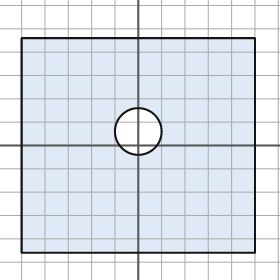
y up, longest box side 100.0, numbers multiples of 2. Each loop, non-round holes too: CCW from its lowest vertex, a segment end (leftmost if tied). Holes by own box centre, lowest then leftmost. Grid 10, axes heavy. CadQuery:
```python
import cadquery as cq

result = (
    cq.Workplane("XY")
    .moveTo(-50.0, -46.0)
    .lineTo(50.0, -46.0)
    .lineTo(50.0, 46.0)
    .lineTo(-50.0, 46.0)
    .close()
    .moveTo(0.0, 6.0)
    .circle(10.0)
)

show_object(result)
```